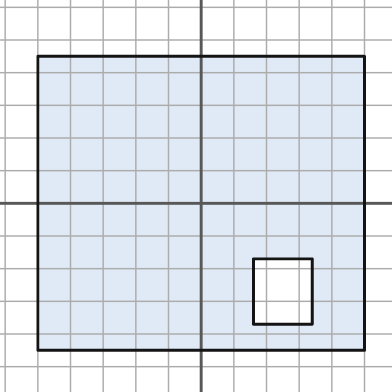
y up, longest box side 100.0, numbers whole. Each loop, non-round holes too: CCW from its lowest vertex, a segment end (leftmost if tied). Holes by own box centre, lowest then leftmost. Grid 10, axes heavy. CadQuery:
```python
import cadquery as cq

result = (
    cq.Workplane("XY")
    .moveTo(-50.0, -45.0)
    .lineTo(50.0, -45.0)
    .lineTo(50.0, 45.0)
    .lineTo(-50.0, 45.0)
    .close()
    .moveTo(16.0, -37.0)
    .lineTo(34.0, -37.0)
    .lineTo(34.0, -17.0)
    .lineTo(16.0, -17.0)
    .close()
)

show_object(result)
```